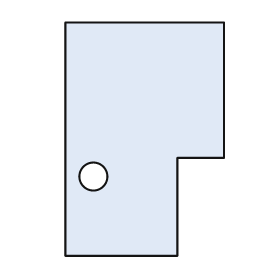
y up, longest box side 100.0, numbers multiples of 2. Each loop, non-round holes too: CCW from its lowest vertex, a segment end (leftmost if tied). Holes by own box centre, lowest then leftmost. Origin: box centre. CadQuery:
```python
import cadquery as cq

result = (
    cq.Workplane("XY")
    .moveTo(-34.0, -50.0)
    .lineTo(14.0, -50.0)
    .lineTo(14.0, -8.0)
    .lineTo(34.0, -8.0)
    .lineTo(34.0, 50.0)
    .lineTo(-34.0, 50.0)
    .close()
    .moveTo(-22.0, -16.0)
    .circle(6.0)
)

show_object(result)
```